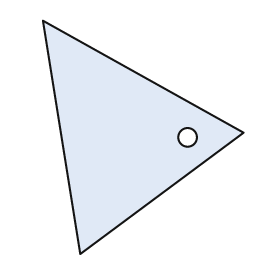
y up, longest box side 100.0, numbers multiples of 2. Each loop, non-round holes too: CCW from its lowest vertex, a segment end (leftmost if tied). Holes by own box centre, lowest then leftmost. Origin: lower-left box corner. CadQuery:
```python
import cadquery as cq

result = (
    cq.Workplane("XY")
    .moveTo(16.0, 0.0)
    .lineTo(86.0, 52.0)
    .lineTo(0.0, 100.0)
    .close()
    .moveTo(62.0, 50.0)
    .circle(4.0)
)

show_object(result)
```